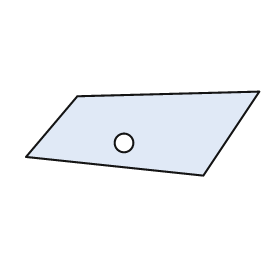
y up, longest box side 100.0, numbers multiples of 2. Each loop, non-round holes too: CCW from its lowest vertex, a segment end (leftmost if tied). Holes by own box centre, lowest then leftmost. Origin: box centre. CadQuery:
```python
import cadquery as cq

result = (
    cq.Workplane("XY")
    .moveTo(26.0, -18.0)
    .lineTo(50.0, 18.0)
    .lineTo(-28.0, 16.0)
    .lineTo(-50.0, -10.0)
    .close()
    .moveTo(-8.0, -4.0)
    .circle(4.0)
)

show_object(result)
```